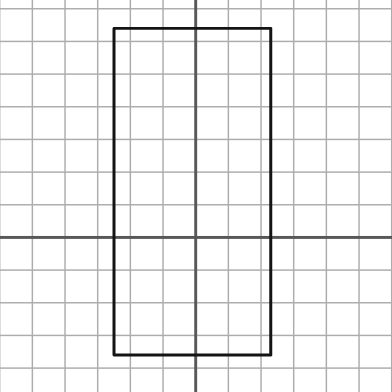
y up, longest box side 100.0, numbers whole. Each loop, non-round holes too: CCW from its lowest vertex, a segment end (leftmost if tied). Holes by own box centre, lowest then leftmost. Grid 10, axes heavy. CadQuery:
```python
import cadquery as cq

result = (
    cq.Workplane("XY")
    .moveTo(-25.0, -36.0)
    .lineTo(23.0, -36.0)
    .lineTo(23.0, 64.0)
    .lineTo(-25.0, 64.0)
    .close()
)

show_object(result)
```